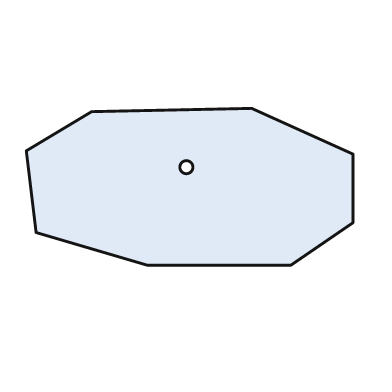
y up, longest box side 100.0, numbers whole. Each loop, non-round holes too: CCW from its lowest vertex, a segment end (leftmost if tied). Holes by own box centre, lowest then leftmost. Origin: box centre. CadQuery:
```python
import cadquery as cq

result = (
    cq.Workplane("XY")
    .moveTo(-13.0, -24.0)
    .lineTo(31.0, -24.0)
    .lineTo(50.0, -11.0)
    .lineTo(50.0, 10.0)
    .lineTo(19.0, 24.0)
    .lineTo(-30.0, 23.0)
    .lineTo(-50.0, 11.0)
    .lineTo(-47.0, -14.0)
    .close()
    .moveTo(-1.0, 6.0)
    .circle(2.0)
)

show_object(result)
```